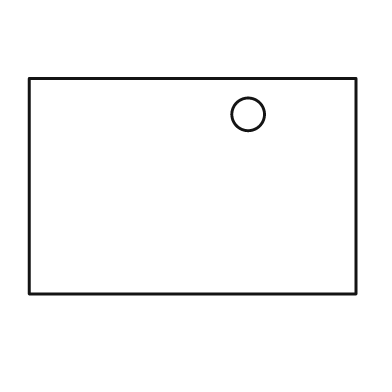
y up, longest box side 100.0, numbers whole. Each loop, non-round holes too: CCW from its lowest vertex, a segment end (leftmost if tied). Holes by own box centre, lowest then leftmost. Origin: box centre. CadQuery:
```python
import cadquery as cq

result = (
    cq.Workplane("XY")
    .moveTo(-50.0, -33.0)
    .lineTo(50.0, -33.0)
    .lineTo(50.0, 33.0)
    .lineTo(-50.0, 33.0)
    .close()
    .moveTo(17.0, 22.0)
    .circle(5.0)
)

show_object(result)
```